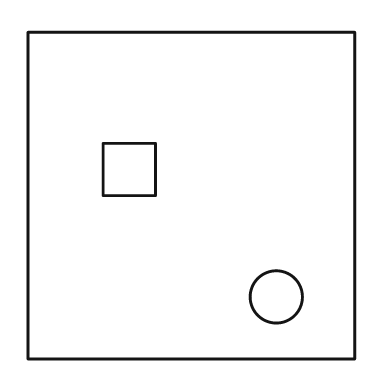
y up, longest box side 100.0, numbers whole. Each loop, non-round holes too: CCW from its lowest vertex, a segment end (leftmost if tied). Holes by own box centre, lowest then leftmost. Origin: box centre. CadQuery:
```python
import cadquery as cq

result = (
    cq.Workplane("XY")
    .moveTo(-50.0, -50.0)
    .lineTo(50.0, -50.0)
    .lineTo(50.0, 50.0)
    .lineTo(-50.0, 50.0)
    .close()
    .moveTo(26.0, -31.0)
    .circle(8.0)
    .moveTo(-27.0, 0.0)
    .lineTo(-11.0, 0.0)
    .lineTo(-11.0, 16.0)
    .lineTo(-27.0, 16.0)
    .close()
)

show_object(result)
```